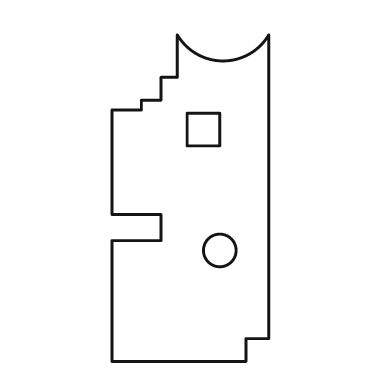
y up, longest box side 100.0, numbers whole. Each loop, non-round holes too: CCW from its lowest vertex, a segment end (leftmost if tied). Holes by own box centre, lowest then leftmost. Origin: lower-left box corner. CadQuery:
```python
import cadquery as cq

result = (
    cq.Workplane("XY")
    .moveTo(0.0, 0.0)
    .lineTo(41.0, 0.0)
    .lineTo(41.0, 7.0)
    .lineTo(48.0, 7.0)
    .lineTo(48.0, 100.0)
    .threePointArc((34.0, 92.0), (20.0, 100.0))
    .lineTo(20.0, 87.0)
    .lineTo(15.0, 87.0)
    .lineTo(15.0, 80.0)
    .lineTo(9.0, 80.0)
    .lineTo(9.0, 77.0)
    .lineTo(0.0, 77.0)
    .lineTo(0.0, 45.0)
    .lineTo(15.0, 45.0)
    .lineTo(15.0, 37.0)
    .lineTo(0.0, 37.0)
    .close()
    .moveTo(33.0, 34.0)
    .circle(5.0)
    .moveTo(23.0, 66.0)
    .lineTo(33.0, 66.0)
    .lineTo(33.0, 76.0)
    .lineTo(23.0, 76.0)
    .close()
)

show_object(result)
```